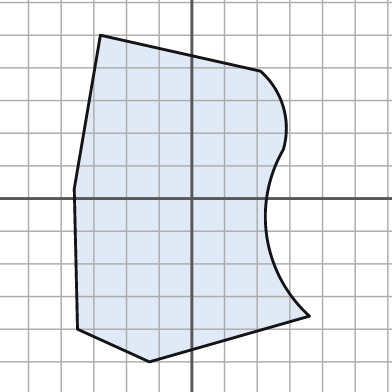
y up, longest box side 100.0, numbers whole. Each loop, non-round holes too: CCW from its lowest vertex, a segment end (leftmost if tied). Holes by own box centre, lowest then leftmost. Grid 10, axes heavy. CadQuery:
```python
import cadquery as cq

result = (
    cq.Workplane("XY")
    .moveTo(-13.0, -50.0)
    .lineTo(36.0, -36.0)
    .threePointArc((23.0, -12.0), (28.0, 15.0))
    .threePointArc((28.0, 28.0), (21.0, 39.0))
    .lineTo(-28.0, 50.0)
    .lineTo(-36.0, 3.0)
    .lineTo(-35.0, -40.0)
    .close()
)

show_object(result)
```